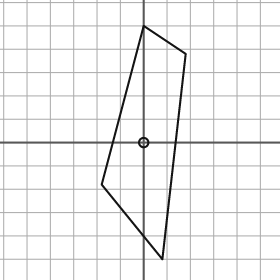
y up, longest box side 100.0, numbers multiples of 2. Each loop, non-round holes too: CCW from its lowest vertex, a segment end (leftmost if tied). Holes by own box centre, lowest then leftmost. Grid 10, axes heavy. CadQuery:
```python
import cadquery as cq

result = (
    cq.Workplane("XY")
    .moveTo(8.0, -50.0)
    .lineTo(18.0, 38.0)
    .lineTo(0.0, 50.0)
    .lineTo(-18.0, -18.0)
    .close()
    .moveTo(0.0, 0.0)
    .circle(2.0)
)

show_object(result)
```